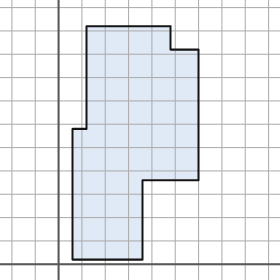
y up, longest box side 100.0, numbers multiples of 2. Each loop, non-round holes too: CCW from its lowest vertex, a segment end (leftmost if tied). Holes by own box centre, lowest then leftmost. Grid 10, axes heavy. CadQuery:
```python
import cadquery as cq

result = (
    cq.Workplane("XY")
    .moveTo(6.0, 2.0)
    .lineTo(36.0, 2.0)
    .lineTo(36.0, 36.0)
    .lineTo(60.0, 36.0)
    .lineTo(60.0, 92.0)
    .lineTo(48.0, 92.0)
    .lineTo(48.0, 102.0)
    .lineTo(12.0, 102.0)
    .lineTo(12.0, 58.0)
    .lineTo(6.0, 58.0)
    .close()
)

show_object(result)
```